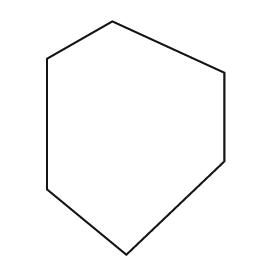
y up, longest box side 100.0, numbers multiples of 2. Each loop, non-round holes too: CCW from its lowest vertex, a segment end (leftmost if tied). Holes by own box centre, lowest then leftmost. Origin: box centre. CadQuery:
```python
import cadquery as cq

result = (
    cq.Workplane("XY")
    .moveTo(-4.0, -50.0)
    .lineTo(38.0, -10.0)
    .lineTo(38.0, 28.0)
    .lineTo(-10.0, 50.0)
    .lineTo(-38.0, 34.0)
    .lineTo(-38.0, -22.0)
    .close()
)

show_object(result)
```